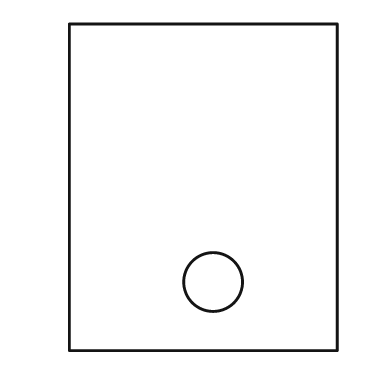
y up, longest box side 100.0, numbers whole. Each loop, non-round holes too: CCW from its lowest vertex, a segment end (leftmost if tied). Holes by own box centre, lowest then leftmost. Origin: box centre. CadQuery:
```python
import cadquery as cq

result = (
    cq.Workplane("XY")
    .moveTo(-41.0, -50.0)
    .lineTo(41.0, -50.0)
    .lineTo(41.0, 50.0)
    .lineTo(-41.0, 50.0)
    .close()
    .moveTo(3.0, -29.0)
    .circle(9.0)
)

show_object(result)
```